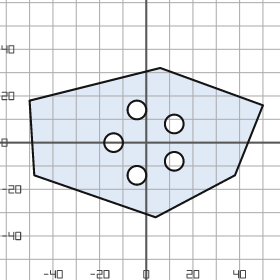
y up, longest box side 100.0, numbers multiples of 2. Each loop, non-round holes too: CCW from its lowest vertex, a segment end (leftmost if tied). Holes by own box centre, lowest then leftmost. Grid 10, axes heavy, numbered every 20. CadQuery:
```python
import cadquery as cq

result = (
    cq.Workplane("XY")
    .moveTo(4.0, -32.0)
    .lineTo(38.0, -14.0)
    .lineTo(50.0, 16.0)
    .lineTo(6.0, 32.0)
    .lineTo(-50.0, 18.0)
    .lineTo(-48.0, -14.0)
    .close()
    .moveTo(-4.0, -14.0)
    .circle(4.0)
    .moveTo(12.0, -8.0)
    .circle(4.0)
    .moveTo(-14.0, 0.0)
    .circle(4.0)
    .moveTo(12.0, 8.0)
    .circle(4.0)
    .moveTo(-4.0, 14.0)
    .circle(4.0)
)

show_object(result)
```